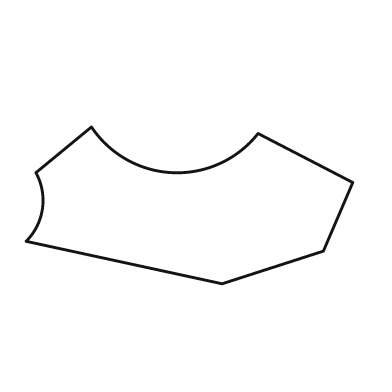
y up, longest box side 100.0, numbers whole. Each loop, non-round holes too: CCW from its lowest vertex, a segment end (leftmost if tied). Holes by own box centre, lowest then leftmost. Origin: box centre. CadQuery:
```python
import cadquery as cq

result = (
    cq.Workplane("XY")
    .moveTo(10.0, -24.0)
    .lineTo(41.0, -14.0)
    .lineTo(50.0, 7.0)
    .lineTo(21.0, 22.0)
    .threePointArc((-5.0, 10.0), (-30.0, 24.0))
    .lineTo(-47.0, 10.0)
    .threePointArc((-45.0, -1.0), (-50.0, -11.0))
    .close()
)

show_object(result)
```